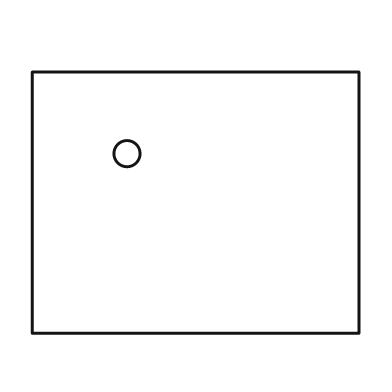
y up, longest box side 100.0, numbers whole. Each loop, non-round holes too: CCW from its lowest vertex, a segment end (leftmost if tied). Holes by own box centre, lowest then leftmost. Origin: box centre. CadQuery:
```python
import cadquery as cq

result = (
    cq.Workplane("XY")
    .moveTo(-50.0, -40.0)
    .lineTo(50.0, -40.0)
    .lineTo(50.0, 40.0)
    .lineTo(-50.0, 40.0)
    .close()
    .moveTo(-21.0, 15.0)
    .circle(4.0)
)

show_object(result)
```